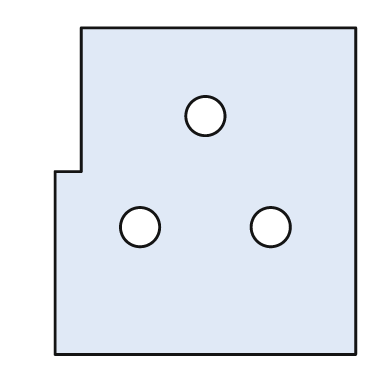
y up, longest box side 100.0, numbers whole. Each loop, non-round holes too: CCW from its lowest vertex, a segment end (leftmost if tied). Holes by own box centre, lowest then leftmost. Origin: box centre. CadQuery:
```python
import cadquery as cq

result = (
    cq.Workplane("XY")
    .moveTo(-46.0, -50.0)
    .lineTo(46.0, -50.0)
    .lineTo(46.0, 50.0)
    .lineTo(-38.0, 50.0)
    .lineTo(-38.0, 6.0)
    .lineTo(-46.0, 6.0)
    .close()
    .moveTo(-20.0, -11.0)
    .circle(6.0)
    .moveTo(20.0, -11.0)
    .circle(6.0)
    .moveTo(0.0, 23.0)
    .circle(6.0)
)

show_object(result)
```